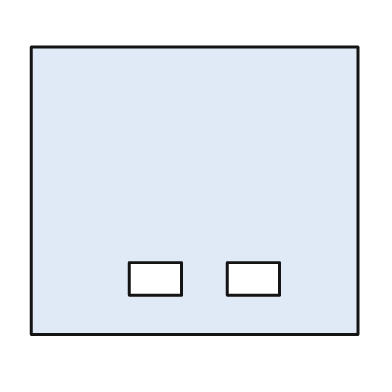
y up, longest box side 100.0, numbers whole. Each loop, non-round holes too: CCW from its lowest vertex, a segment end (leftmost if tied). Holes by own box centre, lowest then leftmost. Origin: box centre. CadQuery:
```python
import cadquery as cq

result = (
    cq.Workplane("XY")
    .moveTo(-50.0, -44.0)
    .lineTo(50.0, -44.0)
    .lineTo(50.0, 44.0)
    .lineTo(-50.0, 44.0)
    .close()
    .moveTo(-20.0, -32.0)
    .lineTo(-4.0, -32.0)
    .lineTo(-4.0, -22.0)
    .lineTo(-20.0, -22.0)
    .close()
    .moveTo(10.0, -32.0)
    .lineTo(26.0, -32.0)
    .lineTo(26.0, -22.0)
    .lineTo(10.0, -22.0)
    .close()
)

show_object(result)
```